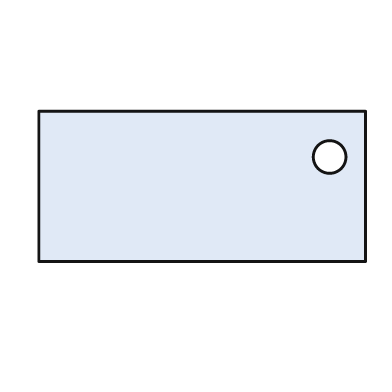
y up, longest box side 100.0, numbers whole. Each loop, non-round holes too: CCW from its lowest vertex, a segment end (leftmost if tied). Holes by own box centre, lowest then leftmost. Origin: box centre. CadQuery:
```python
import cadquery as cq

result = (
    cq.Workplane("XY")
    .moveTo(-50.0, -23.0)
    .lineTo(50.0, -23.0)
    .lineTo(50.0, 23.0)
    .lineTo(-50.0, 23.0)
    .close()
    .moveTo(39.0, 9.0)
    .circle(5.0)
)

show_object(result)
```